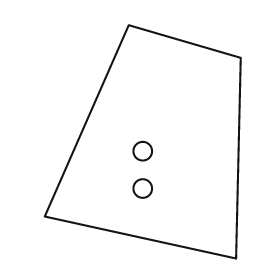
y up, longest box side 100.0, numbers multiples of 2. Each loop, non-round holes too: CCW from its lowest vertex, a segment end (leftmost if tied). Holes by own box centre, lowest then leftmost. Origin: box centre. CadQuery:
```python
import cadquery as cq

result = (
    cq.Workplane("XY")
    .moveTo(40.0, -50.0)
    .lineTo(42.0, 36.0)
    .lineTo(-6.0, 50.0)
    .lineTo(-42.0, -32.0)
    .close()
    .moveTo(0.0, -20.0)
    .circle(4.0)
    .moveTo(0.0, -4.0)
    .circle(4.0)
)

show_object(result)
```